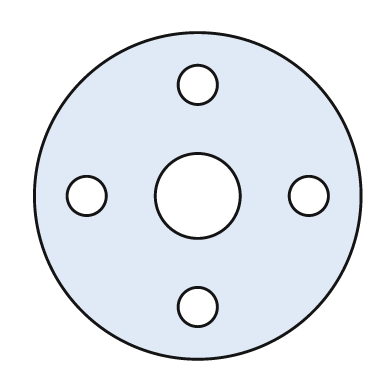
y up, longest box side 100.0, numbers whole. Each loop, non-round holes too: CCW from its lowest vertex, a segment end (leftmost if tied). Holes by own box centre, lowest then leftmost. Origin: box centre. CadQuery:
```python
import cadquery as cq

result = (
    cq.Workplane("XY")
    .moveTo(0.0, 0.0)
    .circle(50.0)
    .moveTo(0.0, -34.0)
    .circle(6.0)
    .moveTo(-34.0, 0.0)
    .circle(6.0)
    .moveTo(0.0, 0.0)
    .circle(13.0)
    .moveTo(34.0, 0.0)
    .circle(6.0)
    .moveTo(0.0, 34.0)
    .circle(6.0)
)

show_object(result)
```